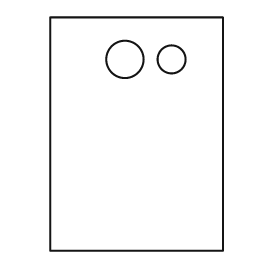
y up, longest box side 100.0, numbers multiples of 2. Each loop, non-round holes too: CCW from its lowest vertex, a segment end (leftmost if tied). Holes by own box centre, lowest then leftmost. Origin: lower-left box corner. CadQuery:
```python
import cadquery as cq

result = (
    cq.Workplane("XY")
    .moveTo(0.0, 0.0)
    .lineTo(74.0, 0.0)
    .lineTo(74.0, 100.0)
    .lineTo(0.0, 100.0)
    .close()
    .moveTo(32.0, 82.0)
    .circle(8.0)
    .moveTo(52.0, 82.0)
    .circle(6.0)
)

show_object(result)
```